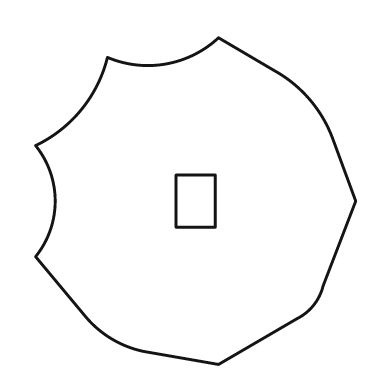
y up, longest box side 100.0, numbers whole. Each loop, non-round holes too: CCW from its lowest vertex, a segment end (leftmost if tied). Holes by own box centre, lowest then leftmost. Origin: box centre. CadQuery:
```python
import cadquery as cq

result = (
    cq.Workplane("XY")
    .moveTo(7.0, -50.0)
    .lineTo(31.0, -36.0)
    .threePointArc((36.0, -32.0), (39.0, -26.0))
    .lineTo(49.0, 0.0)
    .lineTo(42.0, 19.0)
    .threePointArc((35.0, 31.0), (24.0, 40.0))
    .lineTo(7.0, 50.0)
    .threePointArc((-9.0, 42.0), (-27.0, 44.0))
    .threePointArc((-35.0, 28.0), (-49.0, 17.0))
    .threePointArc((-43.0, 0.0), (-49.0, -17.0))
    .lineTo(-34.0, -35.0)
    .threePointArc((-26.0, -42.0), (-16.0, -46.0))
    .close()
    .moveTo(-6.0, -8.0)
    .lineTo(6.0, -8.0)
    .lineTo(6.0, 8.0)
    .lineTo(-6.0, 8.0)
    .close()
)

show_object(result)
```